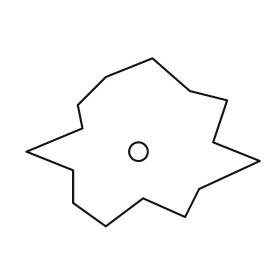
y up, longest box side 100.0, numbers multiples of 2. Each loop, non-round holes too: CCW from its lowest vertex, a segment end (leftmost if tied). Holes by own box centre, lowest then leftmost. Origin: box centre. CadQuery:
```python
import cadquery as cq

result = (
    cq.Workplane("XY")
    .moveTo(-16.0, -36.0)
    .lineTo(0.0, -24.0)
    .lineTo(18.0, -32.0)
    .lineTo(24.0, -20.0)
    .lineTo(50.0, -8.0)
    .lineTo(30.0, 0.0)
    .lineTo(36.0, 18.0)
    .lineTo(20.0, 22.0)
    .lineTo(4.0, 36.0)
    .lineTo(-16.0, 28.0)
    .lineTo(-28.0, 16.0)
    .lineTo(-26.0, 6.0)
    .lineTo(-50.0, -4.0)
    .lineTo(-30.0, -12.0)
    .lineTo(-30.0, -26.0)
    .close()
    .moveTo(-2.0, -4.0)
    .circle(4.0)
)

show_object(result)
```